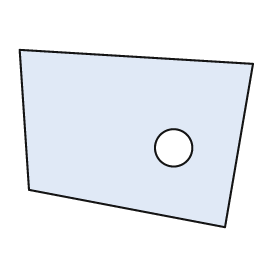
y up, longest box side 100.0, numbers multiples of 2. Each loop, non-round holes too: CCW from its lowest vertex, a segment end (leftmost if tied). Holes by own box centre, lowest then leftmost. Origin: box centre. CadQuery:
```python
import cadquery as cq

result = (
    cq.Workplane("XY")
    .moveTo(38.0, -38.0)
    .lineTo(50.0, 32.0)
    .lineTo(-50.0, 38.0)
    .lineTo(-46.0, -22.0)
    .close()
    .moveTo(16.0, -4.0)
    .circle(8.0)
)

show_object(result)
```